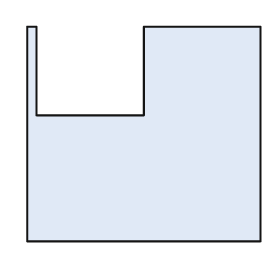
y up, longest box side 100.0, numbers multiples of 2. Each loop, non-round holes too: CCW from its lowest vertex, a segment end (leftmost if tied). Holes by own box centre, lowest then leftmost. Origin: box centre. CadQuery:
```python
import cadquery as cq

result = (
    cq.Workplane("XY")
    .moveTo(-50.0, -46.0)
    .lineTo(50.0, -46.0)
    .lineTo(50.0, 46.0)
    .lineTo(0.0, 46.0)
    .lineTo(0.0, 8.0)
    .lineTo(-46.0, 8.0)
    .lineTo(-46.0, 46.0)
    .lineTo(-50.0, 46.0)
    .close()
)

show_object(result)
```